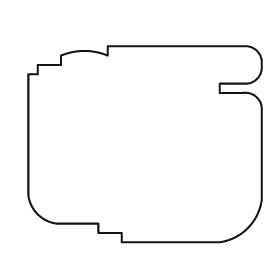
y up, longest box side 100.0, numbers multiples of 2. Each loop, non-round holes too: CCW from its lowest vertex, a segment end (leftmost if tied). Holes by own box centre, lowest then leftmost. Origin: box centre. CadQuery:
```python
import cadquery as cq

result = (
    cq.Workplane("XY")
    .moveTo(-10.0, -42.0)
    .lineTo(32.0, -42.0)
    .threePointArc((44.0, -36.0), (50.0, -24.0))
    .lineTo(50.0, 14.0)
    .threePointArc((48.0, 20.0), (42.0, 22.0))
    .lineTo(32.0, 22.0)
    .lineTo(32.0, 26.0)
    .lineTo(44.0, 26.0)
    .threePointArc((48.0, 28.0), (50.0, 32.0))
    .lineTo(50.0, 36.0)
    .threePointArc((48.0, 40.0), (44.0, 42.0))
    .lineTo(-16.0, 42.0)
    .lineTo(-16.0, 38.0)
    .threePointArc((-26.0, 40.0), (-36.0, 38.0))
    .lineTo(-36.0, 34.0)
    .lineTo(-46.0, 34.0)
    .lineTo(-46.0, 30.0)
    .lineTo(-50.0, 30.0)
    .lineTo(-50.0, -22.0)
    .threePointArc((-46.0, -30.0), (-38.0, -34.0))
    .lineTo(-20.0, -34.0)
    .lineTo(-20.0, -38.0)
    .lineTo(-10.0, -38.0)
    .close()
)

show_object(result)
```